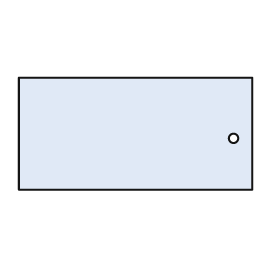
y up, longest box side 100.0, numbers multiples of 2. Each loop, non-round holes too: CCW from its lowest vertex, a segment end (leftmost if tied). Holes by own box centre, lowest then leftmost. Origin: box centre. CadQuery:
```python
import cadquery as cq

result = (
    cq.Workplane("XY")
    .moveTo(-50.0, -24.0)
    .lineTo(50.0, -24.0)
    .lineTo(50.0, 24.0)
    .lineTo(-50.0, 24.0)
    .close()
    .moveTo(42.0, -2.0)
    .circle(2.0)
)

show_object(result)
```